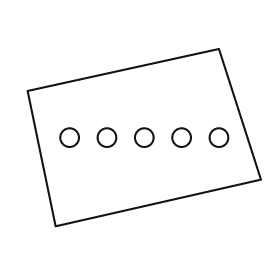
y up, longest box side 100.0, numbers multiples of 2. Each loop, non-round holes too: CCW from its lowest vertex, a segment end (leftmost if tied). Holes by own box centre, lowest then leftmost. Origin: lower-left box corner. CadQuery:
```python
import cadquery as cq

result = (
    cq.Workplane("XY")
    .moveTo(12.0, 0.0)
    .lineTo(100.0, 20.0)
    .lineTo(82.0, 76.0)
    .lineTo(0.0, 58.0)
    .close()
    .moveTo(18.0, 38.0)
    .circle(4.0)
    .moveTo(34.0, 38.0)
    .circle(4.0)
    .moveTo(50.0, 38.0)
    .circle(4.0)
    .moveTo(66.0, 38.0)
    .circle(4.0)
    .moveTo(82.0, 38.0)
    .circle(4.0)
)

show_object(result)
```